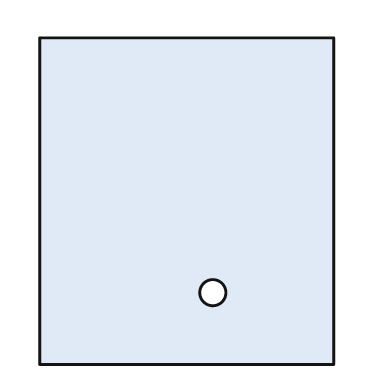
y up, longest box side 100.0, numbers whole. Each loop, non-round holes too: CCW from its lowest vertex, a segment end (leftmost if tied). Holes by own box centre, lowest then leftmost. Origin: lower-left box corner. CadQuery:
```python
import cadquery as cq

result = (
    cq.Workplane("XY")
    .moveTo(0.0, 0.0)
    .lineTo(90.0, 0.0)
    .lineTo(90.0, 100.0)
    .lineTo(0.0, 100.0)
    .close()
    .moveTo(53.0, 22.0)
    .circle(4.0)
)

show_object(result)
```